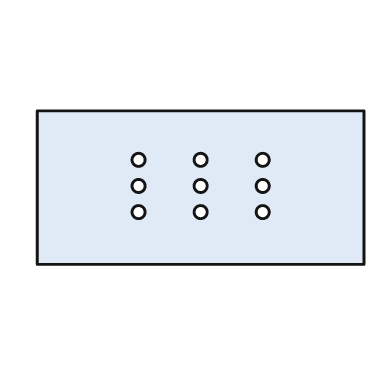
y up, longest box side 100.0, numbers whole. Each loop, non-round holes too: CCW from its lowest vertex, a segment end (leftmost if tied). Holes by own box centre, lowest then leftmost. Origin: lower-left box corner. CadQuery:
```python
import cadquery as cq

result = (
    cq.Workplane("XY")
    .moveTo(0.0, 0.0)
    .lineTo(100.0, 0.0)
    .lineTo(100.0, 47.0)
    .lineTo(0.0, 47.0)
    .close()
    .moveTo(31.0, 16.0)
    .circle(2.0)
    .moveTo(50.0, 16.0)
    .circle(2.0)
    .moveTo(69.0, 16.0)
    .circle(2.0)
    .moveTo(31.0, 24.0)
    .circle(2.0)
    .moveTo(50.0, 24.0)
    .circle(2.0)
    .moveTo(69.0, 24.0)
    .circle(2.0)
    .moveTo(31.0, 32.0)
    .circle(2.0)
    .moveTo(50.0, 32.0)
    .circle(2.0)
    .moveTo(69.0, 32.0)
    .circle(2.0)
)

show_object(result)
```